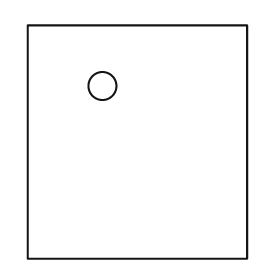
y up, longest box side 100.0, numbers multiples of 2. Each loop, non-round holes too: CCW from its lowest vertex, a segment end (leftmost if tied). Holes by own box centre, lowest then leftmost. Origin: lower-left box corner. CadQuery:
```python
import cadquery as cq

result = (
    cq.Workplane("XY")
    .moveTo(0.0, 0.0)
    .lineTo(94.0, 0.0)
    .lineTo(94.0, 100.0)
    .lineTo(0.0, 100.0)
    .close()
    .moveTo(32.0, 74.0)
    .circle(6.0)
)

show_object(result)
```